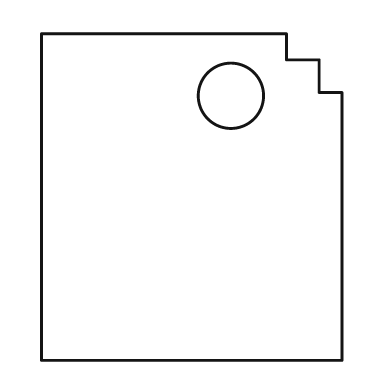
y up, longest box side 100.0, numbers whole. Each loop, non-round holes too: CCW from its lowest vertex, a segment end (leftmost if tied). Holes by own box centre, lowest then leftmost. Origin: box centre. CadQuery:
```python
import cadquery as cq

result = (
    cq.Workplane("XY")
    .moveTo(-46.0, -50.0)
    .lineTo(46.0, -50.0)
    .lineTo(46.0, 32.0)
    .lineTo(39.0, 32.0)
    .lineTo(39.0, 42.0)
    .lineTo(29.0, 42.0)
    .lineTo(29.0, 50.0)
    .lineTo(-46.0, 50.0)
    .close()
    .moveTo(12.0, 31.0)
    .circle(10.0)
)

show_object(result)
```